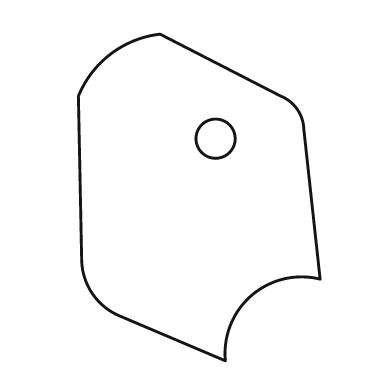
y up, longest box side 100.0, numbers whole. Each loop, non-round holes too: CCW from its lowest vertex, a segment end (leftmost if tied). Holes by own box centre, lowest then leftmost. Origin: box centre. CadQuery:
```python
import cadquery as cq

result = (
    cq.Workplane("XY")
    .moveTo(8.0, -50.0)
    .threePointArc((16.0, -30.0), (37.0, -25.0))
    .lineTo(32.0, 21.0)
    .threePointArc((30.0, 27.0), (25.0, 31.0))
    .lineTo(-12.0, 50.0)
    .threePointArc((-27.0, 44.0), (-37.0, 31.0))
    .lineTo(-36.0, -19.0)
    .threePointArc((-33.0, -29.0), (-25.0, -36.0))
    .close()
    .moveTo(5.0, 18.0)
    .circle(6.0)
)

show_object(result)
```